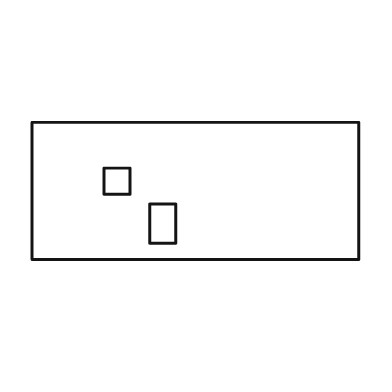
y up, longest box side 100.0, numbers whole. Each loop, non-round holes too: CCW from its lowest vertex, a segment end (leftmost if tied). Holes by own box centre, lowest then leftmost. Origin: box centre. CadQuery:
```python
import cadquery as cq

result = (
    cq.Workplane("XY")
    .moveTo(-50.0, -21.0)
    .lineTo(50.0, -21.0)
    .lineTo(50.0, 21.0)
    .lineTo(-50.0, 21.0)
    .close()
    .moveTo(-14.0, -16.0)
    .lineTo(-6.0, -16.0)
    .lineTo(-6.0, -4.0)
    .lineTo(-14.0, -4.0)
    .close()
    .moveTo(-28.0, -1.0)
    .lineTo(-20.0, -1.0)
    .lineTo(-20.0, 7.0)
    .lineTo(-28.0, 7.0)
    .close()
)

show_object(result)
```